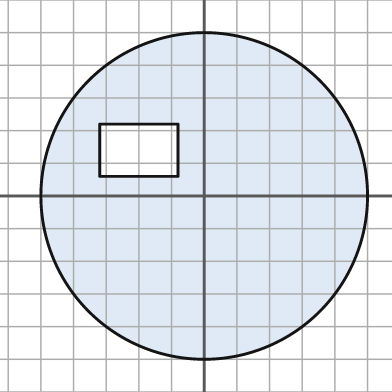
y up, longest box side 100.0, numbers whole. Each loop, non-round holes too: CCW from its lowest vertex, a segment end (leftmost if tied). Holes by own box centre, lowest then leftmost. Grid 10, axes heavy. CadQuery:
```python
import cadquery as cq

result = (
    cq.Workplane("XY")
    .moveTo(0.0, 0.0)
    .circle(50.0)
    .moveTo(-32.0, 6.0)
    .lineTo(-8.0, 6.0)
    .lineTo(-8.0, 22.0)
    .lineTo(-32.0, 22.0)
    .close()
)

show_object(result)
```